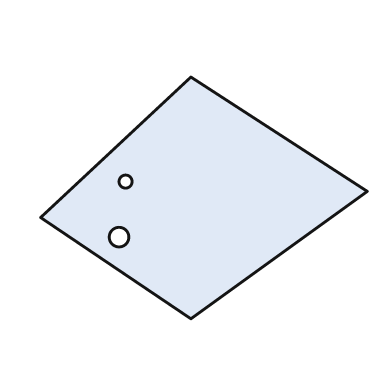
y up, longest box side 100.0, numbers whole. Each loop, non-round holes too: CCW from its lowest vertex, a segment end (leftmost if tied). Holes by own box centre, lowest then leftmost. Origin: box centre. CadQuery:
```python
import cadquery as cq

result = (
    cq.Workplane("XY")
    .moveTo(-4.0, -37.0)
    .lineTo(50.0, 2.0)
    .lineTo(-4.0, 37.0)
    .lineTo(-50.0, -6.0)
    .close()
    .moveTo(-26.0, -12.0)
    .circle(3.0)
    .moveTo(-24.0, 5.0)
    .circle(2.0)
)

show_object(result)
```